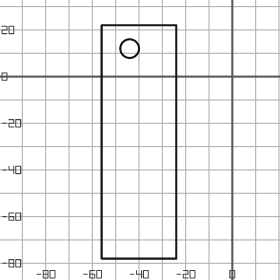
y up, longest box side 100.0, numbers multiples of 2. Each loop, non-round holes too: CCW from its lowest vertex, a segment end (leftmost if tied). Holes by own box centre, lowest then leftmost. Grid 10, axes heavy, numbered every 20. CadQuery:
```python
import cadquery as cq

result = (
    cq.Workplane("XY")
    .moveTo(-56.0, -78.0)
    .lineTo(-24.0, -78.0)
    .lineTo(-24.0, 22.0)
    .lineTo(-56.0, 22.0)
    .close()
    .moveTo(-44.0, 12.0)
    .circle(4.0)
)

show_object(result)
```